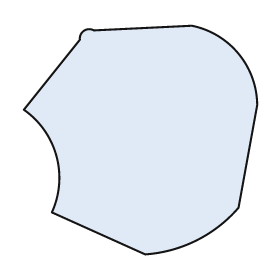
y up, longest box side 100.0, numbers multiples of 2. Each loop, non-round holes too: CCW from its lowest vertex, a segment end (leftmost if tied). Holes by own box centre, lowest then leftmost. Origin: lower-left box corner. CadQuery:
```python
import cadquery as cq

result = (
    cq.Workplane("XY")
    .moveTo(52.0, 0.0)
    .threePointArc((74.0, 6.0), (92.0, 20.0))
    .lineTo(100.0, 64.0)
    .threePointArc((92.0, 86.0), (72.0, 98.0))
    .lineTo(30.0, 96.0)
    .threePointArc((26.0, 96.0), (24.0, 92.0))
    .lineTo(0.0, 62.0)
    .threePointArc((14.0, 42.0), (12.0, 18.0))
    .close()
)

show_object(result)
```